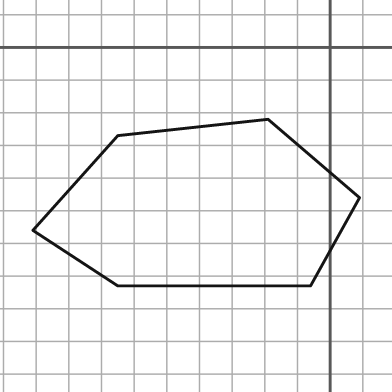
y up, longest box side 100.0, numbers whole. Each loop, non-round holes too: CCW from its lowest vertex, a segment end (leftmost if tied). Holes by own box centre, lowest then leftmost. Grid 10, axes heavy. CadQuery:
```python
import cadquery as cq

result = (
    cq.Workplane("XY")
    .moveTo(-65.0, -73.0)
    .lineTo(-6.0, -73.0)
    .lineTo(9.0, -46.0)
    .lineTo(-19.0, -22.0)
    .lineTo(-65.0, -27.0)
    .lineTo(-91.0, -56.0)
    .close()
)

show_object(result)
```